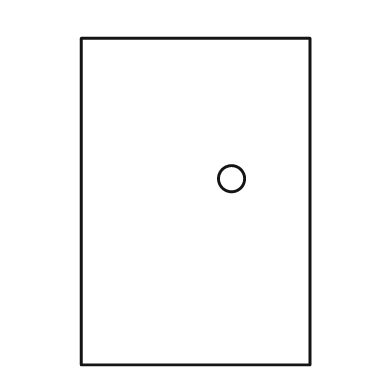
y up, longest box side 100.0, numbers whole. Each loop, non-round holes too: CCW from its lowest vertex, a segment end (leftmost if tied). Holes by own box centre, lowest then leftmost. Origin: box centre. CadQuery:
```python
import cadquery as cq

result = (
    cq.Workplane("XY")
    .moveTo(-35.0, -50.0)
    .lineTo(35.0, -50.0)
    .lineTo(35.0, 50.0)
    .lineTo(-35.0, 50.0)
    .close()
    .moveTo(11.0, 7.0)
    .circle(4.0)
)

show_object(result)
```